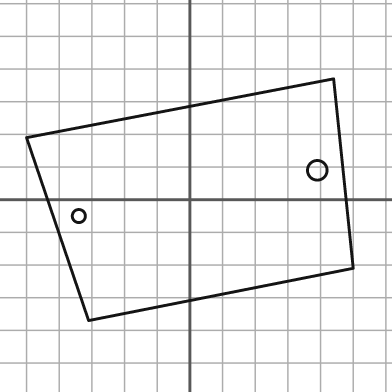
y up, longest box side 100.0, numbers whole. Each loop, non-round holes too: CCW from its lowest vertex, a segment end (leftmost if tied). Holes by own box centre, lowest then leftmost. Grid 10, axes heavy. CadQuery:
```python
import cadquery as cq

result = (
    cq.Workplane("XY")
    .moveTo(-31.0, -37.0)
    .lineTo(50.0, -21.0)
    .lineTo(44.0, 37.0)
    .lineTo(-50.0, 19.0)
    .close()
    .moveTo(-34.0, -5.0)
    .circle(2.0)
    .moveTo(39.0, 9.0)
    .circle(3.0)
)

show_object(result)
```